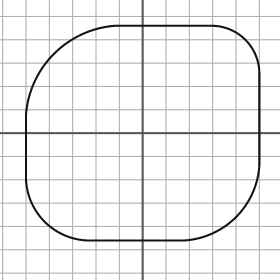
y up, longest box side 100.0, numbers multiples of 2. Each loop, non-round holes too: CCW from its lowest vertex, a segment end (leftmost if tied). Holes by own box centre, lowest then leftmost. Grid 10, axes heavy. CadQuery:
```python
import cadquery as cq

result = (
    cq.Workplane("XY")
    .moveTo(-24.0, -46.0)
    .lineTo(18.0, -46.0)
    .threePointArc((40.0, -36.0), (50.0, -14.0))
    .lineTo(50.0, 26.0)
    .threePointArc((44.0, 40.0), (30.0, 46.0))
    .lineTo(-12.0, 46.0)
    .threePointArc((-38.0, 34.0), (-50.0, 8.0))
    .lineTo(-50.0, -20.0)
    .threePointArc((-42.0, -38.0), (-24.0, -46.0))
    .close()
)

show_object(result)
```